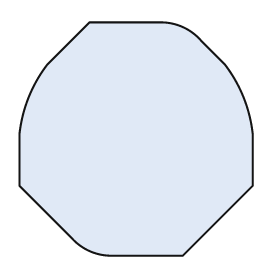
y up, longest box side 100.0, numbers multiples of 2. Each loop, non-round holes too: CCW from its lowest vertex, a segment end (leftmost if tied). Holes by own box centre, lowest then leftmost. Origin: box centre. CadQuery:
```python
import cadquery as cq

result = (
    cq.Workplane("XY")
    .moveTo(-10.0, -50.0)
    .lineTo(20.0, -50.0)
    .lineTo(50.0, -20.0)
    .lineTo(50.0, 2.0)
    .threePointArc((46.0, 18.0), (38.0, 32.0))
    .lineTo(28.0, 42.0)
    .threePointArc((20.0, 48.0), (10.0, 50.0))
    .lineTo(-20.0, 50.0)
    .lineTo(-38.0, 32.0)
    .threePointArc((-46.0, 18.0), (-50.0, 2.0))
    .lineTo(-50.0, -20.0)
    .lineTo(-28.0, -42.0)
    .threePointArc((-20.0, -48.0), (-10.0, -50.0))
    .close()
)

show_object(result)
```